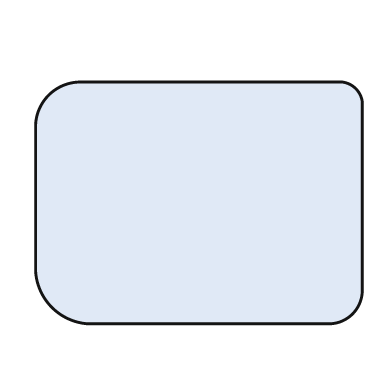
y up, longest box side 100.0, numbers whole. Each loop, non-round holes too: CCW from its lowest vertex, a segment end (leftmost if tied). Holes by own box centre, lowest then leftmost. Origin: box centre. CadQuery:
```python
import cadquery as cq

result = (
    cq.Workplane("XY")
    .moveTo(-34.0, -37.0)
    .lineTo(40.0, -37.0)
    .threePointArc((47.0, -34.0), (50.0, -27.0))
    .lineTo(50.0, 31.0)
    .threePointArc((48.0, 35.0), (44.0, 37.0))
    .lineTo(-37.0, 37.0)
    .threePointArc((-46.0, 33.0), (-50.0, 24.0))
    .lineTo(-50.0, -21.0)
    .threePointArc((-45.0, -32.0), (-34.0, -37.0))
    .close()
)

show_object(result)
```